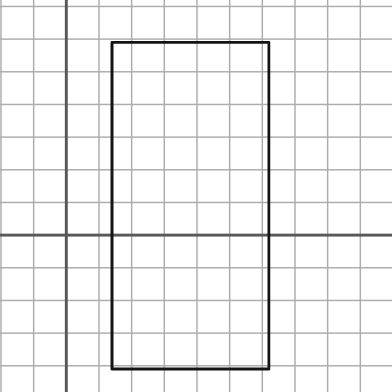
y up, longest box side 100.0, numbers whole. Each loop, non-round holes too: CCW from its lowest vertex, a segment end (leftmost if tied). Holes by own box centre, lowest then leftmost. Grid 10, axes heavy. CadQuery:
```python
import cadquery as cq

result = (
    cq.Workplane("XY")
    .moveTo(14.0, -41.0)
    .lineTo(62.0, -41.0)
    .lineTo(62.0, 59.0)
    .lineTo(14.0, 59.0)
    .close()
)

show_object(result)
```